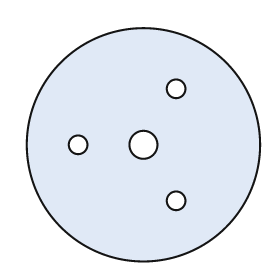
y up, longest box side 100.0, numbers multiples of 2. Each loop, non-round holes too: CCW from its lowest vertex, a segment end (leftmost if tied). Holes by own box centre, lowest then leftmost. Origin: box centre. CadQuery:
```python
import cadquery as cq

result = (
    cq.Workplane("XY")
    .moveTo(0.0, 0.0)
    .circle(50.0)
    .moveTo(14.0, -24.0)
    .circle(4.0)
    .moveTo(-28.0, 0.0)
    .circle(4.0)
    .moveTo(0.0, 0.0)
    .circle(6.0)
    .moveTo(14.0, 24.0)
    .circle(4.0)
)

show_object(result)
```